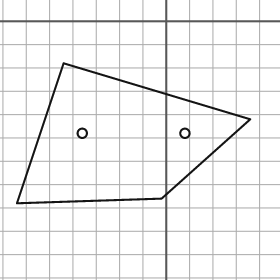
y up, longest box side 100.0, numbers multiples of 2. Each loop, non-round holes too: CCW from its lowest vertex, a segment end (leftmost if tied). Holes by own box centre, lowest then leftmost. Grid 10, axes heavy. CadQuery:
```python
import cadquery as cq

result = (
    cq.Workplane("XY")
    .moveTo(-64.0, -78.0)
    .lineTo(-2.0, -76.0)
    .lineTo(36.0, -42.0)
    .lineTo(-44.0, -18.0)
    .close()
    .moveTo(-36.0, -48.0)
    .circle(2.0)
    .moveTo(8.0, -48.0)
    .circle(2.0)
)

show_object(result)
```